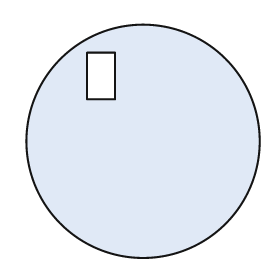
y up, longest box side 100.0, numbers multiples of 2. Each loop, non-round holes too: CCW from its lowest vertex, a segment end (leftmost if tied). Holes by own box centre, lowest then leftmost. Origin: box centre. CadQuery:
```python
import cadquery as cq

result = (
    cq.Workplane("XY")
    .moveTo(0.0, 0.0)
    .circle(50.0)
    .moveTo(-24.0, 18.0)
    .lineTo(-12.0, 18.0)
    .lineTo(-12.0, 38.0)
    .lineTo(-24.0, 38.0)
    .close()
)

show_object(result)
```